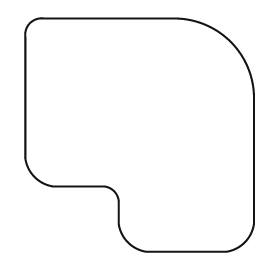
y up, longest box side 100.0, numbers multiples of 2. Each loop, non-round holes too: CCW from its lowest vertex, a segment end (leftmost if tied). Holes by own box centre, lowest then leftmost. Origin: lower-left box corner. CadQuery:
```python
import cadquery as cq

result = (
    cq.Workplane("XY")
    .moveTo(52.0, 0.0)
    .lineTo(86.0, 0.0)
    .threePointArc((94.0, 4.0), (98.0, 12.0))
    .lineTo(98.0, 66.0)
    .threePointArc((88.0, 90.0), (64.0, 100.0))
    .lineTo(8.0, 100.0)
    .threePointArc((2.0, 98.0), (0.0, 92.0))
    .lineTo(0.0, 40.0)
    .threePointArc((4.0, 32.0), (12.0, 28.0))
    .lineTo(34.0, 28.0)
    .threePointArc((38.0, 26.0), (40.0, 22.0))
    .lineTo(40.0, 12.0)
    .threePointArc((44.0, 4.0), (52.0, 0.0))
    .close()
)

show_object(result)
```